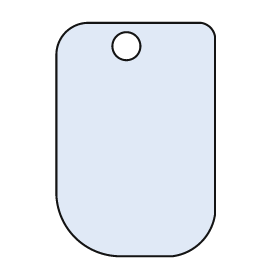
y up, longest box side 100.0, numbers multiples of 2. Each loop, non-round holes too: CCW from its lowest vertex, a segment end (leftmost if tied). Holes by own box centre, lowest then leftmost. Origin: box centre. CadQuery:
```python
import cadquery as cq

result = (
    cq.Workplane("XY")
    .moveTo(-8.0, -50.0)
    .lineTo(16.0, -50.0)
    .threePointArc((28.0, -44.0), (34.0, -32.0))
    .lineTo(34.0, 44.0)
    .threePointArc((32.0, 48.0), (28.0, 50.0))
    .lineTo(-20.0, 50.0)
    .threePointArc((-30.0, 46.0), (-34.0, 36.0))
    .lineTo(-34.0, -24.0)
    .threePointArc((-26.0, -42.0), (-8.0, -50.0))
    .close()
    .moveTo(-4.0, 40.0)
    .circle(6.0)
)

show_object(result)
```